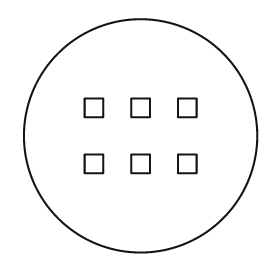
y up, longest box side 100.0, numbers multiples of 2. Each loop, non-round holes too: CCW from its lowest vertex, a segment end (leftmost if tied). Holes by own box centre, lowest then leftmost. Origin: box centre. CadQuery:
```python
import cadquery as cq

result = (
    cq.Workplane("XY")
    .moveTo(0.0, 0.0)
    .circle(50.0)
    .moveTo(-24.0, -16.0)
    .lineTo(-16.0, -16.0)
    .lineTo(-16.0, -8.0)
    .lineTo(-24.0, -8.0)
    .close()
    .moveTo(-4.0, -16.0)
    .lineTo(4.0, -16.0)
    .lineTo(4.0, -8.0)
    .lineTo(-4.0, -8.0)
    .close()
    .moveTo(16.0, -16.0)
    .lineTo(24.0, -16.0)
    .lineTo(24.0, -8.0)
    .lineTo(16.0, -8.0)
    .close()
    .moveTo(-24.0, 8.0)
    .lineTo(-16.0, 8.0)
    .lineTo(-16.0, 16.0)
    .lineTo(-24.0, 16.0)
    .close()
    .moveTo(-4.0, 8.0)
    .lineTo(4.0, 8.0)
    .lineTo(4.0, 16.0)
    .lineTo(-4.0, 16.0)
    .close()
    .moveTo(16.0, 8.0)
    .lineTo(24.0, 8.0)
    .lineTo(24.0, 16.0)
    .lineTo(16.0, 16.0)
    .close()
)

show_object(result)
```